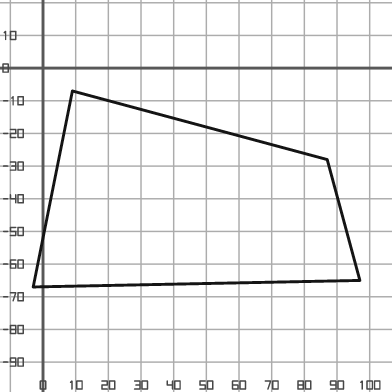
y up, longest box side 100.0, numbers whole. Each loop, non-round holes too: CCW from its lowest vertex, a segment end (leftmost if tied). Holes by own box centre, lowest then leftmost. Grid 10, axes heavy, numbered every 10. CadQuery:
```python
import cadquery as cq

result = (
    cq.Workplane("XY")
    .moveTo(-3.0, -67.0)
    .lineTo(97.0, -65.0)
    .lineTo(87.0, -28.0)
    .lineTo(9.0, -7.0)
    .close()
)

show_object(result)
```